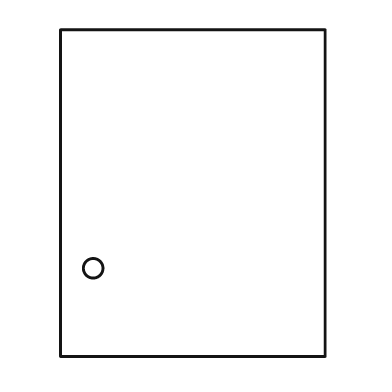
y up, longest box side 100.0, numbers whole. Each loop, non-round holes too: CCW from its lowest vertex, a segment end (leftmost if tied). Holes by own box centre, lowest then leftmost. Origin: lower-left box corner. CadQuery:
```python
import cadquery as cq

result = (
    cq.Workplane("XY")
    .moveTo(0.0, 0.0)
    .lineTo(81.0, 0.0)
    .lineTo(81.0, 100.0)
    .lineTo(0.0, 100.0)
    .close()
    .moveTo(10.0, 27.0)
    .circle(3.0)
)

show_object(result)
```